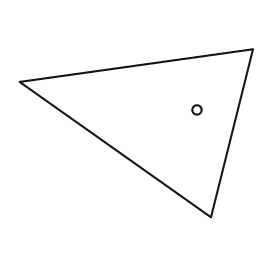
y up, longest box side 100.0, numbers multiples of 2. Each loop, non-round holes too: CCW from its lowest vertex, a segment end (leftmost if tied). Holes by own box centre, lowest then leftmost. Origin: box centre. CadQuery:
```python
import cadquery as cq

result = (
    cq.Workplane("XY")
    .moveTo(32.0, -36.0)
    .lineTo(50.0, 36.0)
    .lineTo(-50.0, 22.0)
    .close()
    .moveTo(26.0, 10.0)
    .circle(2.0)
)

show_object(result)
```